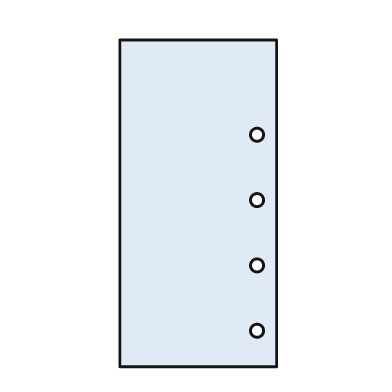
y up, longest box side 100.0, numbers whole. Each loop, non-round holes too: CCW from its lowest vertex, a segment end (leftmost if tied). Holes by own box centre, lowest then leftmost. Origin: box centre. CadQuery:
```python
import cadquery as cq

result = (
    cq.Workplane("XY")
    .moveTo(-24.0, -50.0)
    .lineTo(24.0, -50.0)
    .lineTo(24.0, 50.0)
    .lineTo(-24.0, 50.0)
    .close()
    .moveTo(18.0, -39.0)
    .circle(2.0)
    .moveTo(18.0, -19.0)
    .circle(2.0)
    .moveTo(18.0, 1.0)
    .circle(2.0)
    .moveTo(18.0, 21.0)
    .circle(2.0)
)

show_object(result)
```